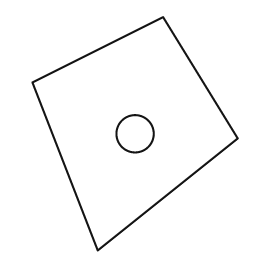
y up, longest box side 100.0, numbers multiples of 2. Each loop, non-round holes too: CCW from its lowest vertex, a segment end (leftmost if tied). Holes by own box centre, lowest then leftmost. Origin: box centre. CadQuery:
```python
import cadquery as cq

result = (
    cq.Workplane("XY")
    .moveTo(-16.0, -50.0)
    .lineTo(44.0, -2.0)
    .lineTo(12.0, 50.0)
    .lineTo(-44.0, 22.0)
    .close()
    .moveTo(0.0, 0.0)
    .circle(8.0)
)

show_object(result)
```